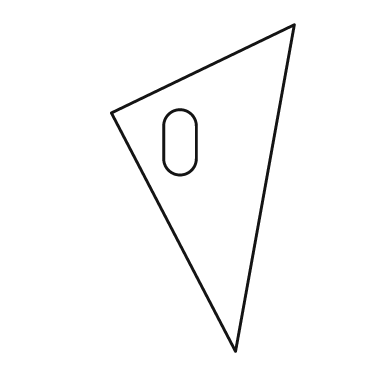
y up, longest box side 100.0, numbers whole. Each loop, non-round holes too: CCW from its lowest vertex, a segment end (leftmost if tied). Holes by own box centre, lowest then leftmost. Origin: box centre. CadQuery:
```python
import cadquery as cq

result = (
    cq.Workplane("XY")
    .moveTo(10.0, -50.0)
    .lineTo(28.0, 50.0)
    .lineTo(-28.0, 23.0)
    .close()
    .moveTo(-12.0, 9.0)
    .threePointArc((-7.0, 4.0), (-2.0, 9.0))
    .lineTo(-2.0, 19.0)
    .threePointArc((-7.0, 24.0), (-12.0, 19.0))
    .close()
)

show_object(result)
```